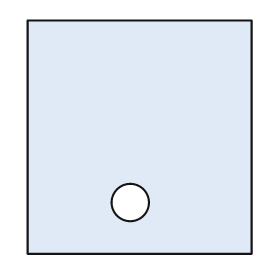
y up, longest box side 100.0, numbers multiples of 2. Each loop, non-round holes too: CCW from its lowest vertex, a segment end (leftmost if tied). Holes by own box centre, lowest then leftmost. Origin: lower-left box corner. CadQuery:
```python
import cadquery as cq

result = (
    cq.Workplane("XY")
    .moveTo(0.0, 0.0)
    .lineTo(96.0, 0.0)
    .lineTo(96.0, 100.0)
    .lineTo(0.0, 100.0)
    .close()
    .moveTo(44.0, 22.0)
    .circle(8.0)
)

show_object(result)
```